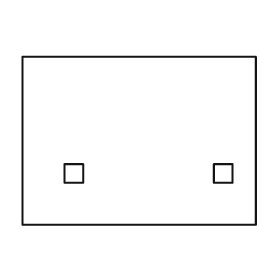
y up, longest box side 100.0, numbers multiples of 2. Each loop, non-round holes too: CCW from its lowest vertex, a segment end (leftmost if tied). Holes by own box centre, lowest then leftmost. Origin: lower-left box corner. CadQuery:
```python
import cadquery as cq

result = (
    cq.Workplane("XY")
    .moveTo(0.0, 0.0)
    .lineTo(100.0, 0.0)
    .lineTo(100.0, 72.0)
    .lineTo(0.0, 72.0)
    .close()
    .moveTo(18.0, 18.0)
    .lineTo(26.0, 18.0)
    .lineTo(26.0, 26.0)
    .lineTo(18.0, 26.0)
    .close()
    .moveTo(82.0, 18.0)
    .lineTo(90.0, 18.0)
    .lineTo(90.0, 26.0)
    .lineTo(82.0, 26.0)
    .close()
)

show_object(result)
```